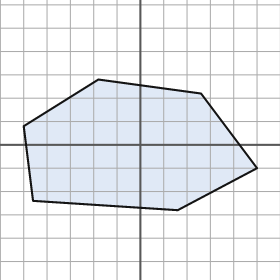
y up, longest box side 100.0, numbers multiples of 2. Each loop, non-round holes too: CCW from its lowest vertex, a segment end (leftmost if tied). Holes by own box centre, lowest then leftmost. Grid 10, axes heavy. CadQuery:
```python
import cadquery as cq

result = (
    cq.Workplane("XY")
    .moveTo(16.0, -28.0)
    .lineTo(50.0, -10.0)
    .lineTo(26.0, 22.0)
    .lineTo(-18.0, 28.0)
    .lineTo(-50.0, 8.0)
    .lineTo(-46.0, -24.0)
    .close()
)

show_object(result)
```